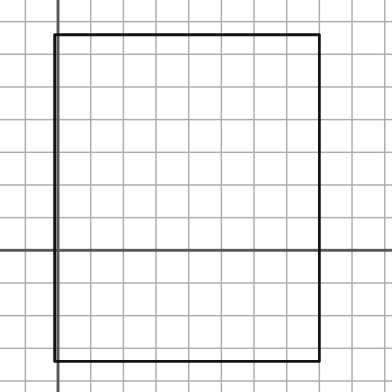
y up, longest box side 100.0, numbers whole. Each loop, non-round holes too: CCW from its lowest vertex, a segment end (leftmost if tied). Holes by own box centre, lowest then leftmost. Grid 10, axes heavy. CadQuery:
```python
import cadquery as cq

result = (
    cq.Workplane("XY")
    .moveTo(-1.0, -34.0)
    .lineTo(80.0, -34.0)
    .lineTo(80.0, 66.0)
    .lineTo(-1.0, 66.0)
    .close()
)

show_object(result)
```